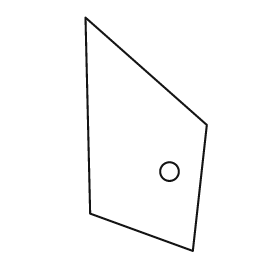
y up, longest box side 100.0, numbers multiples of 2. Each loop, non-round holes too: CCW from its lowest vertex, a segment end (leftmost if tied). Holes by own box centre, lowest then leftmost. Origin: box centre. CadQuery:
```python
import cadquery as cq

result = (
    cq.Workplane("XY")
    .moveTo(20.0, -50.0)
    .lineTo(26.0, 4.0)
    .lineTo(-26.0, 50.0)
    .lineTo(-24.0, -34.0)
    .close()
    .moveTo(10.0, -16.0)
    .circle(4.0)
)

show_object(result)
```